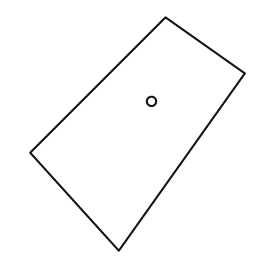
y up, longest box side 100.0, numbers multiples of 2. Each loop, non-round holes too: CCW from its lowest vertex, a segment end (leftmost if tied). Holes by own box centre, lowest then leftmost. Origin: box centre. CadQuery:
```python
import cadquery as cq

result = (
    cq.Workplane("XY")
    .moveTo(-8.0, -50.0)
    .lineTo(46.0, 26.0)
    .lineTo(12.0, 50.0)
    .lineTo(-46.0, -8.0)
    .close()
    .moveTo(6.0, 14.0)
    .circle(2.0)
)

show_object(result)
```